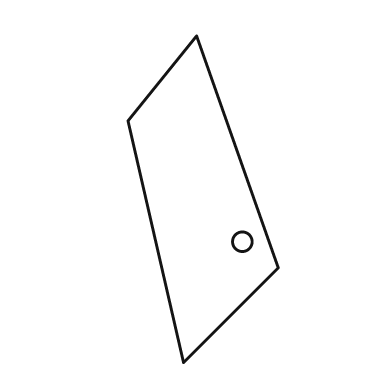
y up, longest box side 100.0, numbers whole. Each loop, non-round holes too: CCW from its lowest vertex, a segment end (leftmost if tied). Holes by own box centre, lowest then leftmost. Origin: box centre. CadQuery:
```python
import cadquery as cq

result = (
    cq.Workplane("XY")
    .moveTo(-6.0, -50.0)
    .lineTo(23.0, -21.0)
    .lineTo(-2.0, 50.0)
    .lineTo(-23.0, 24.0)
    .close()
    .moveTo(12.0, -13.0)
    .circle(3.0)
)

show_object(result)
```